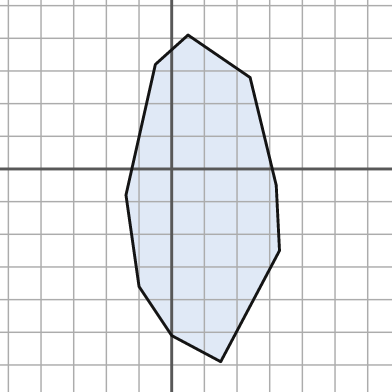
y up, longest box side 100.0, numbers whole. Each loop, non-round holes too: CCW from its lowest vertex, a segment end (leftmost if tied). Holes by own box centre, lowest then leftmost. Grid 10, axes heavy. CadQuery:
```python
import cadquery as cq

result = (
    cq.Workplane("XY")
    .moveTo(15.0, -59.0)
    .lineTo(33.0, -25.0)
    .lineTo(32.0, -5.0)
    .lineTo(24.0, 28.0)
    .lineTo(5.0, 41.0)
    .lineTo(-5.0, 32.0)
    .lineTo(-14.0, -8.0)
    .lineTo(-10.0, -36.0)
    .lineTo(0.0, -51.0)
    .close()
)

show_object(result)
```